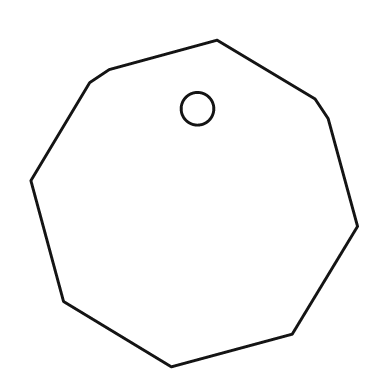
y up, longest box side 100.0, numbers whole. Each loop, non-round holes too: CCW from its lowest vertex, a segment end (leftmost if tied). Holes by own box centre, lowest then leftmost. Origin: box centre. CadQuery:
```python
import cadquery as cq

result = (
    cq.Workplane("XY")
    .moveTo(-7.0, -50.0)
    .lineTo(30.0, -40.0)
    .lineTo(50.0, -7.0)
    .lineTo(41.0, 26.0)
    .lineTo(37.0, 32.0)
    .lineTo(7.0, 50.0)
    .lineTo(-26.0, 41.0)
    .lineTo(-32.0, 37.0)
    .lineTo(-50.0, 7.0)
    .lineTo(-40.0, -30.0)
    .close()
    .moveTo(1.0, 29.0)
    .circle(5.0)
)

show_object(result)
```